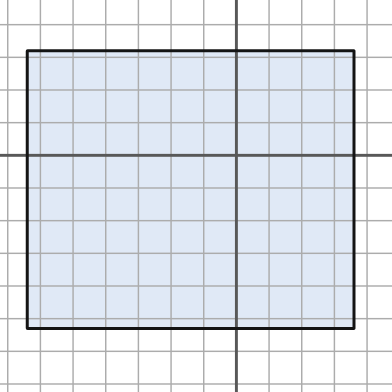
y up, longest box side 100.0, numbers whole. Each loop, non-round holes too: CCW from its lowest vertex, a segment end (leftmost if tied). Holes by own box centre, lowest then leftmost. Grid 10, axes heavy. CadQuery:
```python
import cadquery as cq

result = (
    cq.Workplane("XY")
    .moveTo(-64.0, -53.0)
    .lineTo(36.0, -53.0)
    .lineTo(36.0, 32.0)
    .lineTo(-64.0, 32.0)
    .close()
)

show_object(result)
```